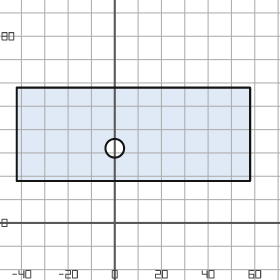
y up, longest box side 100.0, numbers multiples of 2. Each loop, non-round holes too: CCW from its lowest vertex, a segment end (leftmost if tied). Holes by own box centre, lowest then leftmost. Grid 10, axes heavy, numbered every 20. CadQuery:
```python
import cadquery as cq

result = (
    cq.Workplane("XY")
    .moveTo(-42.0, 18.0)
    .lineTo(58.0, 18.0)
    .lineTo(58.0, 58.0)
    .lineTo(-42.0, 58.0)
    .close()
    .moveTo(0.0, 32.0)
    .circle(4.0)
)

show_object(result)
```